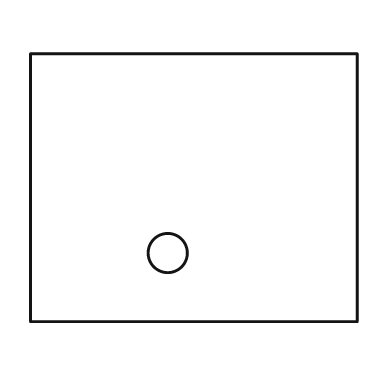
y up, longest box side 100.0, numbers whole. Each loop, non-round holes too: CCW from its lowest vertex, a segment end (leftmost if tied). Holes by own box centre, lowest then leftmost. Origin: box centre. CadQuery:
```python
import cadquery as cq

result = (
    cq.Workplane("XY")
    .moveTo(-50.0, -41.0)
    .lineTo(50.0, -41.0)
    .lineTo(50.0, 41.0)
    .lineTo(-50.0, 41.0)
    .close()
    .moveTo(-8.0, -20.0)
    .circle(6.0)
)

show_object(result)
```